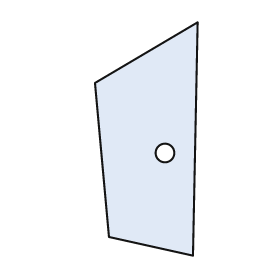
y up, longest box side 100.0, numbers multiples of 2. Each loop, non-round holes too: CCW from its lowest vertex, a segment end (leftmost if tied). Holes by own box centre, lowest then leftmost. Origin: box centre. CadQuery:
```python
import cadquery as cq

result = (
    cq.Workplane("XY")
    .moveTo(20.0, -50.0)
    .lineTo(22.0, 50.0)
    .lineTo(-22.0, 24.0)
    .lineTo(-16.0, -42.0)
    .close()
    .moveTo(8.0, -6.0)
    .circle(4.0)
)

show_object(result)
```